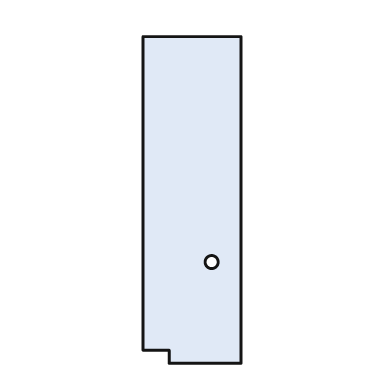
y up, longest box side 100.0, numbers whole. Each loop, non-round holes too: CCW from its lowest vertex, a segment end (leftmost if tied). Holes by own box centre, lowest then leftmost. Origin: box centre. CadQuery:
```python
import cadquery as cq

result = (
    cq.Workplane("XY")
    .moveTo(-7.0, -50.0)
    .lineTo(15.0, -50.0)
    .lineTo(15.0, 50.0)
    .lineTo(-15.0, 50.0)
    .lineTo(-15.0, -46.0)
    .lineTo(-7.0, -46.0)
    .close()
    .moveTo(6.0, -19.0)
    .circle(2.0)
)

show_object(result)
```